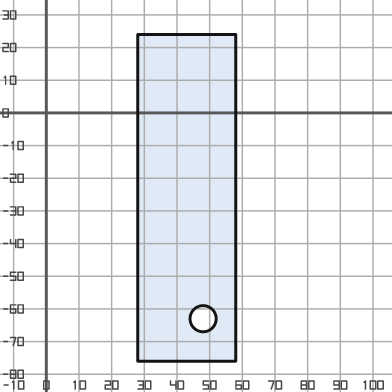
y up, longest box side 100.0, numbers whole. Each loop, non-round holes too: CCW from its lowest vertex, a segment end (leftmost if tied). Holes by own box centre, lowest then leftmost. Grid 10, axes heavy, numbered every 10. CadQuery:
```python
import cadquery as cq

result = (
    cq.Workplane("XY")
    .moveTo(28.0, -76.0)
    .lineTo(58.0, -76.0)
    .lineTo(58.0, 24.0)
    .lineTo(28.0, 24.0)
    .close()
    .moveTo(48.0, -63.0)
    .circle(4.0)
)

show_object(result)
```